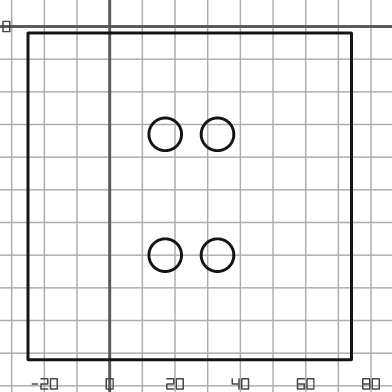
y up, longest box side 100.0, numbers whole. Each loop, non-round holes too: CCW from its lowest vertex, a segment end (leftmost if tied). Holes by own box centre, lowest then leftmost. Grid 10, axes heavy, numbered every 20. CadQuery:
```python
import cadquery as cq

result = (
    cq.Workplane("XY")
    .moveTo(-25.0, -102.0)
    .lineTo(74.0, -102.0)
    .lineTo(74.0, -2.0)
    .lineTo(-25.0, -2.0)
    .close()
    .moveTo(17.0, -70.0)
    .circle(5.0)
    .moveTo(33.0, -70.0)
    .circle(5.0)
    .moveTo(17.0, -33.0)
    .circle(5.0)
    .moveTo(33.0, -33.0)
    .circle(5.0)
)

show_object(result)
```